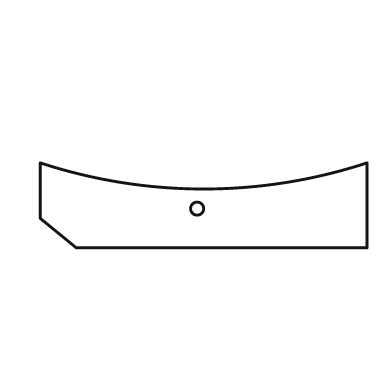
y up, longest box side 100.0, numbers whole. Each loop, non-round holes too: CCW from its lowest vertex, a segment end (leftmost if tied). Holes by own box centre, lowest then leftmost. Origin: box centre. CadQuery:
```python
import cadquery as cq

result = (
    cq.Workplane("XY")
    .moveTo(-39.0, -13.0)
    .lineTo(50.0, -13.0)
    .lineTo(50.0, 13.0)
    .threePointArc((0.0, 5.0), (-50.0, 13.0))
    .lineTo(-50.0, -4.0)
    .close()
    .moveTo(-2.0, -1.0)
    .circle(2.0)
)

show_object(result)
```